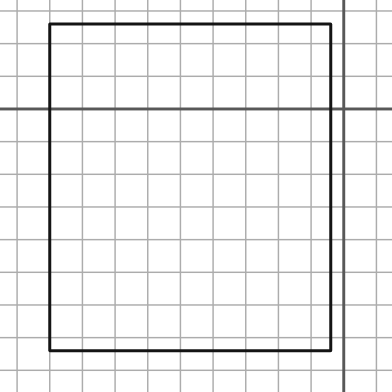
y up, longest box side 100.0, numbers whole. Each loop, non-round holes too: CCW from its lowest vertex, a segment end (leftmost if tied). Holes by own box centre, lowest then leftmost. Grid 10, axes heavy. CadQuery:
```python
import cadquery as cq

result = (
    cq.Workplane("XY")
    .moveTo(-90.0, -74.0)
    .lineTo(-4.0, -74.0)
    .lineTo(-4.0, 26.0)
    .lineTo(-90.0, 26.0)
    .close()
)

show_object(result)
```